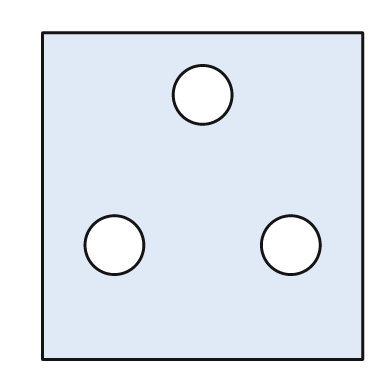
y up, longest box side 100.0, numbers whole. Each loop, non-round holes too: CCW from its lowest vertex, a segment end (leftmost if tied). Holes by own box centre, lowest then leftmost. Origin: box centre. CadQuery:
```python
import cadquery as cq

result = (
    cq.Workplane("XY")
    .moveTo(-49.0, -50.0)
    .lineTo(49.0, -50.0)
    .lineTo(49.0, 50.0)
    .lineTo(-49.0, 50.0)
    .close()
    .moveTo(-27.0, -15.0)
    .circle(9.0)
    .moveTo(27.0, -15.0)
    .circle(9.0)
    .moveTo(0.0, 31.0)
    .circle(9.0)
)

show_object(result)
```